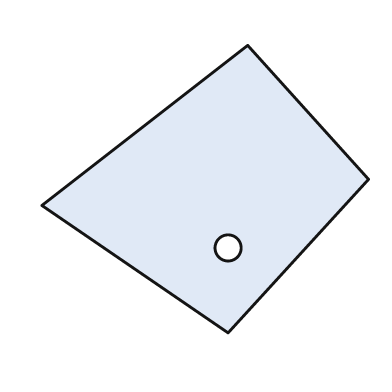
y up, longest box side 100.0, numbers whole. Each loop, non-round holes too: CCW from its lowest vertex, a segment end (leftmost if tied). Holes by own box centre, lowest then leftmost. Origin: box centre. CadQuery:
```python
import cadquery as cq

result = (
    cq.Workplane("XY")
    .moveTo(7.0, -44.0)
    .lineTo(50.0, 3.0)
    .lineTo(13.0, 44.0)
    .lineTo(-50.0, -5.0)
    .close()
    .moveTo(7.0, -18.0)
    .circle(4.0)
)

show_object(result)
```